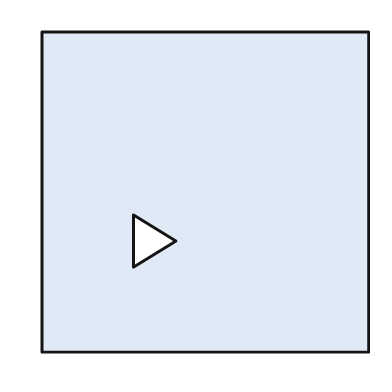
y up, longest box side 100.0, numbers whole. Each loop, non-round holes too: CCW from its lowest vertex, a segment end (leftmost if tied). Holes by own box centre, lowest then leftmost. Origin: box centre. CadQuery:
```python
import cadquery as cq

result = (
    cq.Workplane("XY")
    .moveTo(-50.0, -49.0)
    .lineTo(50.0, -49.0)
    .lineTo(50.0, 49.0)
    .lineTo(-50.0, 49.0)
    .close()
    .moveTo(-22.0, -23.0)
    .lineTo(-9.0, -15.0)
    .lineTo(-22.0, -7.0)
    .close()
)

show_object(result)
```